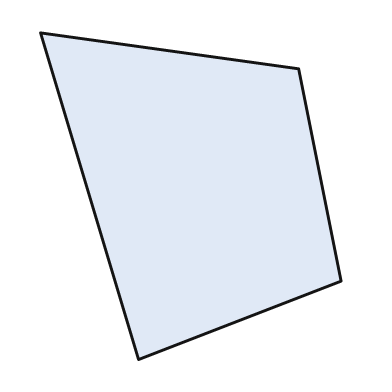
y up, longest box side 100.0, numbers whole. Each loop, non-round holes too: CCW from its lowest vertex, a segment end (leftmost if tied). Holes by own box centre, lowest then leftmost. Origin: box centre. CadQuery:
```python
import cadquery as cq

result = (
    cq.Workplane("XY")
    .moveTo(-16.0, -50.0)
    .lineTo(46.0, -26.0)
    .lineTo(33.0, 39.0)
    .lineTo(-46.0, 50.0)
    .close()
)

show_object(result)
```